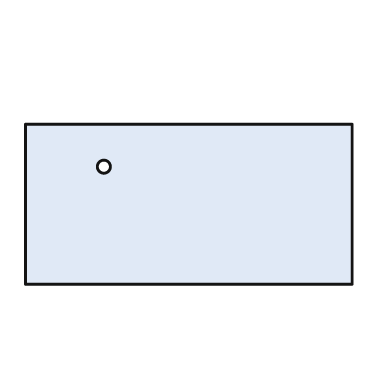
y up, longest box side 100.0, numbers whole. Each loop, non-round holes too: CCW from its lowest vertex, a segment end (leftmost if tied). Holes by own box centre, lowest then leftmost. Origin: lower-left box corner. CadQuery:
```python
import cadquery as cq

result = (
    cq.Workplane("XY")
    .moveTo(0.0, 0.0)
    .lineTo(100.0, 0.0)
    .lineTo(100.0, 49.0)
    .lineTo(0.0, 49.0)
    .close()
    .moveTo(24.0, 36.0)
    .circle(2.0)
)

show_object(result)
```